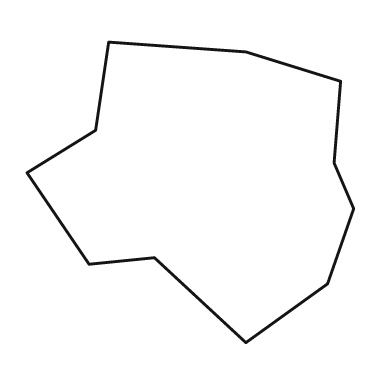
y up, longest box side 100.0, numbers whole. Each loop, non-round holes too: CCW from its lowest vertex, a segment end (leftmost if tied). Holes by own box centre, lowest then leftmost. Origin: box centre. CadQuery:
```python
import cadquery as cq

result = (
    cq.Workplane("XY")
    .moveTo(17.0, -46.0)
    .lineTo(42.0, -28.0)
    .lineTo(50.0, -5.0)
    .lineTo(44.0, 9.0)
    .lineTo(46.0, 34.0)
    .lineTo(17.0, 43.0)
    .lineTo(-25.0, 46.0)
    .lineTo(-29.0, 19.0)
    .lineTo(-50.0, 6.0)
    .lineTo(-31.0, -22.0)
    .lineTo(-11.0, -20.0)
    .close()
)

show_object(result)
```